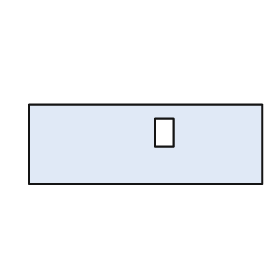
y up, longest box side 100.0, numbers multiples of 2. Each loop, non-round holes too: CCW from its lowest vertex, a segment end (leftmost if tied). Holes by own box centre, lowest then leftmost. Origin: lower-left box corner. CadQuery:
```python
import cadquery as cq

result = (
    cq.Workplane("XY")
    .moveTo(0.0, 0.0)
    .lineTo(100.0, 0.0)
    .lineTo(100.0, 34.0)
    .lineTo(0.0, 34.0)
    .close()
    .moveTo(54.0, 16.0)
    .lineTo(62.0, 16.0)
    .lineTo(62.0, 28.0)
    .lineTo(54.0, 28.0)
    .close()
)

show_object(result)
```